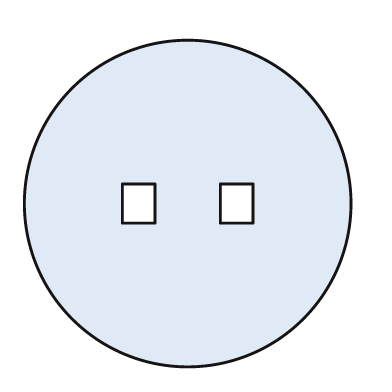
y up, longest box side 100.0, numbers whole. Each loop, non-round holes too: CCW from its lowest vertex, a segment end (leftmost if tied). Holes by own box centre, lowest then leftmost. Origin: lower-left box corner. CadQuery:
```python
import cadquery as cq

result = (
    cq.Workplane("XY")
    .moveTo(50.0, 50.0)
    .circle(50.0)
    .moveTo(30.0, 44.0)
    .lineTo(40.0, 44.0)
    .lineTo(40.0, 56.0)
    .lineTo(30.0, 56.0)
    .close()
    .moveTo(60.0, 44.0)
    .lineTo(70.0, 44.0)
    .lineTo(70.0, 56.0)
    .lineTo(60.0, 56.0)
    .close()
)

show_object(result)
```